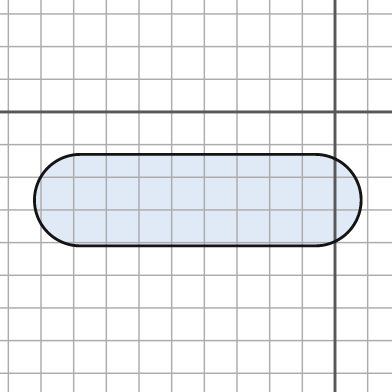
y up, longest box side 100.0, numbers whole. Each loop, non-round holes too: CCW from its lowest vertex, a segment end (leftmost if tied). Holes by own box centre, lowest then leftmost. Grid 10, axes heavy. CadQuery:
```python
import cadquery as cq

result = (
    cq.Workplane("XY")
    .moveTo(-78.0, -41.0)
    .lineTo(-6.0, -41.0)
    .threePointArc((8.0, -27.0), (-6.0, -13.0))
    .lineTo(-78.0, -13.0)
    .threePointArc((-92.0, -27.0), (-78.0, -41.0))
    .close()
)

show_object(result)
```